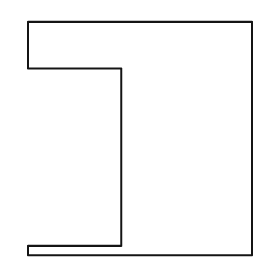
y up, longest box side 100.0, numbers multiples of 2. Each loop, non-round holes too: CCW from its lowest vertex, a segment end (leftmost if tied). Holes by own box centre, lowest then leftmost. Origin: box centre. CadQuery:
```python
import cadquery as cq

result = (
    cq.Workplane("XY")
    .moveTo(-48.0, -50.0)
    .lineTo(48.0, -50.0)
    .lineTo(48.0, 50.0)
    .lineTo(-48.0, 50.0)
    .lineTo(-48.0, 30.0)
    .lineTo(-8.0, 30.0)
    .lineTo(-8.0, -46.0)
    .lineTo(-48.0, -46.0)
    .close()
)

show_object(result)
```